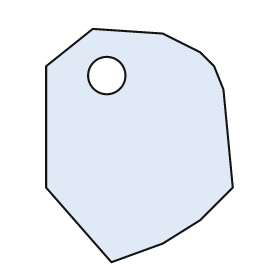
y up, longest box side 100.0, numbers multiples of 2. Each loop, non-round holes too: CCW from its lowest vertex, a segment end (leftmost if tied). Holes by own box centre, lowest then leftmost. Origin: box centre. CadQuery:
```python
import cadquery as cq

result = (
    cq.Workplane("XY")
    .moveTo(-12.0, -50.0)
    .lineTo(10.0, -42.0)
    .lineTo(26.0, -32.0)
    .lineTo(40.0, -18.0)
    .lineTo(36.0, 24.0)
    .lineTo(32.0, 34.0)
    .lineTo(26.0, 40.0)
    .lineTo(10.0, 48.0)
    .lineTo(-20.0, 50.0)
    .lineTo(-40.0, 34.0)
    .lineTo(-40.0, -18.0)
    .close()
    .moveTo(-14.0, 30.0)
    .circle(8.0)
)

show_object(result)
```